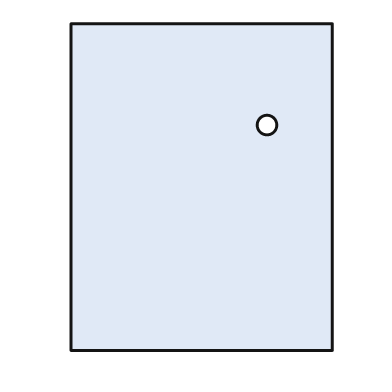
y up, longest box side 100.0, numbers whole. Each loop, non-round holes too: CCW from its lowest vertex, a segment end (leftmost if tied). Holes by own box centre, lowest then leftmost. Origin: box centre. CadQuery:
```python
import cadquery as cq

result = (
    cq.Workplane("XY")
    .moveTo(-40.0, -50.0)
    .lineTo(40.0, -50.0)
    .lineTo(40.0, 50.0)
    .lineTo(-40.0, 50.0)
    .close()
    .moveTo(20.0, 19.0)
    .circle(3.0)
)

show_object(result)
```